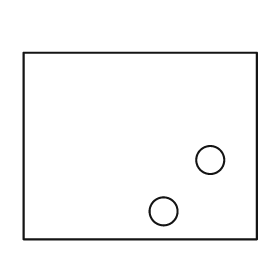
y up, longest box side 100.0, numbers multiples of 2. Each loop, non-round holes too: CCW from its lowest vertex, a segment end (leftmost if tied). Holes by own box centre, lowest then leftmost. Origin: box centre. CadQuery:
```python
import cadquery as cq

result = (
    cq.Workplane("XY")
    .moveTo(-50.0, -40.0)
    .lineTo(50.0, -40.0)
    .lineTo(50.0, 40.0)
    .lineTo(-50.0, 40.0)
    .close()
    .moveTo(10.0, -28.0)
    .circle(6.0)
    .moveTo(30.0, -6.0)
    .circle(6.0)
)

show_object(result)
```